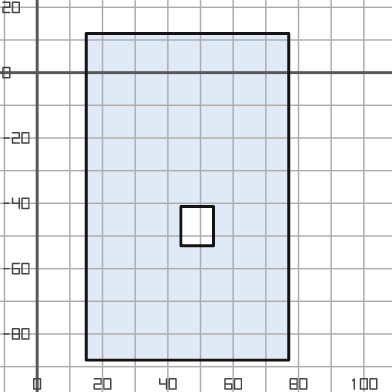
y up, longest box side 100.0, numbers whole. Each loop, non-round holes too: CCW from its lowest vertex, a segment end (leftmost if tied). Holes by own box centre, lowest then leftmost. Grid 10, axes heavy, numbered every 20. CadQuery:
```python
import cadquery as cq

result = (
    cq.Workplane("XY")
    .moveTo(15.0, -88.0)
    .lineTo(77.0, -88.0)
    .lineTo(77.0, 12.0)
    .lineTo(15.0, 12.0)
    .close()
    .moveTo(44.0, -53.0)
    .lineTo(54.0, -53.0)
    .lineTo(54.0, -41.0)
    .lineTo(44.0, -41.0)
    .close()
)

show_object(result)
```